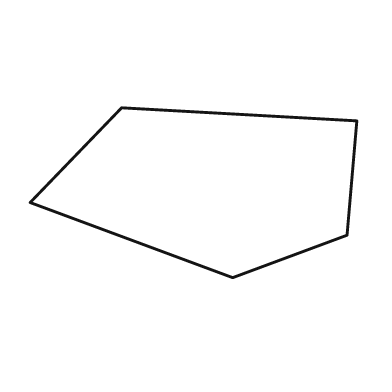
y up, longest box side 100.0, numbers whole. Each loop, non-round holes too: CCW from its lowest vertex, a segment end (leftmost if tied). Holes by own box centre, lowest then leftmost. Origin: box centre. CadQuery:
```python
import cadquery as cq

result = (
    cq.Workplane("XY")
    .moveTo(12.0, -26.0)
    .lineTo(47.0, -13.0)
    .lineTo(50.0, 22.0)
    .lineTo(-22.0, 26.0)
    .lineTo(-50.0, -3.0)
    .close()
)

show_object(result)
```